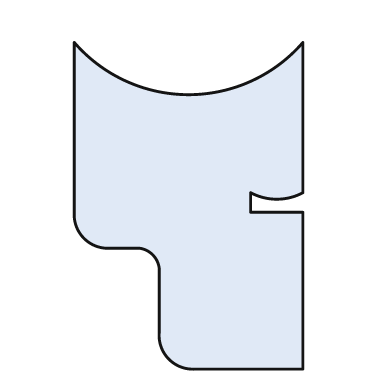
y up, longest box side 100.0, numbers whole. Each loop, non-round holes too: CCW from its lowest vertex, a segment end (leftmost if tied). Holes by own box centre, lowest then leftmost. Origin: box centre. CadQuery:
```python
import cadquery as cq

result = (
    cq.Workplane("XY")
    .moveTo(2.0, -50.0)
    .lineTo(35.0, -50.0)
    .lineTo(35.0, -2.0)
    .lineTo(19.0, -2.0)
    .lineTo(19.0, 4.0)
    .threePointArc((27.0, 2.0), (35.0, 4.0))
    .lineTo(35.0, 50.0)
    .threePointArc((0.0, 34.0), (-35.0, 50.0))
    .lineTo(-35.0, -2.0)
    .threePointArc((-32.0, -10.0), (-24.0, -13.0))
    .lineTo(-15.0, -13.0)
    .threePointArc((-11.0, -15.0), (-9.0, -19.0))
    .lineTo(-9.0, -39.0)
    .threePointArc((-6.0, -47.0), (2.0, -50.0))
    .close()
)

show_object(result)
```